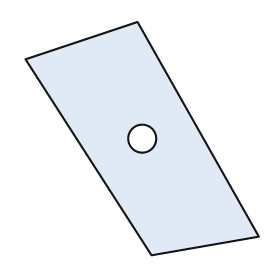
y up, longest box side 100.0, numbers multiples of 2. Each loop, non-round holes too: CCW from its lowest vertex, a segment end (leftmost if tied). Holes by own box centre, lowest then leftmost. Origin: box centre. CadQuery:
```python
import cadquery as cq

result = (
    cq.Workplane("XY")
    .moveTo(4.0, -50.0)
    .lineTo(50.0, -42.0)
    .lineTo(-2.0, 50.0)
    .lineTo(-50.0, 34.0)
    .close()
    .moveTo(0.0, 0.0)
    .circle(6.0)
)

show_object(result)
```